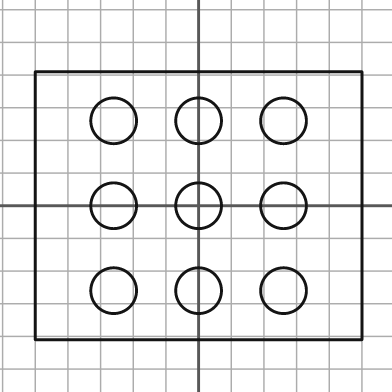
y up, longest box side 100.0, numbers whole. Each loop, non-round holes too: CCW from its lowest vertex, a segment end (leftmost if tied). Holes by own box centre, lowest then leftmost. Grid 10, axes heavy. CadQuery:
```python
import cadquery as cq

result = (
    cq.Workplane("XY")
    .moveTo(-50.0, -41.0)
    .lineTo(50.0, -41.0)
    .lineTo(50.0, 41.0)
    .lineTo(-50.0, 41.0)
    .close()
    .moveTo(-26.0, -26.0)
    .circle(7.0)
    .moveTo(0.0, -26.0)
    .circle(7.0)
    .moveTo(26.0, -26.0)
    .circle(7.0)
    .moveTo(-26.0, 0.0)
    .circle(7.0)
    .moveTo(0.0, 0.0)
    .circle(7.0)
    .moveTo(26.0, 0.0)
    .circle(7.0)
    .moveTo(-26.0, 26.0)
    .circle(7.0)
    .moveTo(0.0, 26.0)
    .circle(7.0)
    .moveTo(26.0, 26.0)
    .circle(7.0)
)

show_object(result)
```